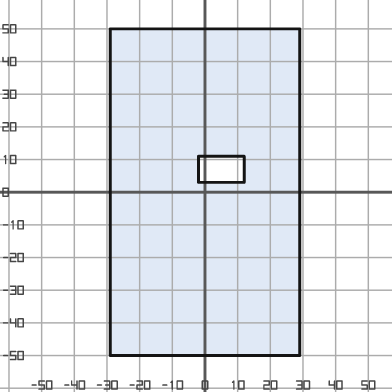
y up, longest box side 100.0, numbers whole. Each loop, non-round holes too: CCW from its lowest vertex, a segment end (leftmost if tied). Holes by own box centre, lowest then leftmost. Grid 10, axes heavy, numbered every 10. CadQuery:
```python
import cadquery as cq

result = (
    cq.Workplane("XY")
    .moveTo(-29.0, -50.0)
    .lineTo(29.0, -50.0)
    .lineTo(29.0, 50.0)
    .lineTo(-29.0, 50.0)
    .close()
    .moveTo(-2.0, 3.0)
    .lineTo(12.0, 3.0)
    .lineTo(12.0, 11.0)
    .lineTo(-2.0, 11.0)
    .close()
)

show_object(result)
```